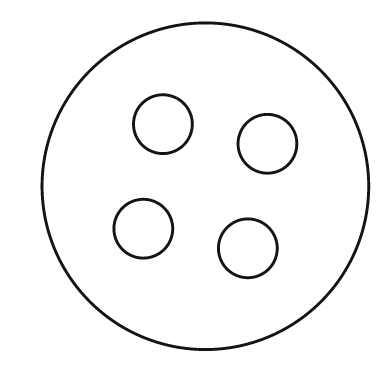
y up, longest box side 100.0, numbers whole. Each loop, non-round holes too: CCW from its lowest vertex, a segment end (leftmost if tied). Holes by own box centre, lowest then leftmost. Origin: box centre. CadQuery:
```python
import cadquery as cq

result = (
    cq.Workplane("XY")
    .moveTo(0.0, 0.0)
    .circle(50.0)
    .moveTo(13.0, -19.0)
    .circle(9.0)
    .moveTo(-19.0, -13.0)
    .circle(9.0)
    .moveTo(19.0, 13.0)
    .circle(9.0)
    .moveTo(-13.0, 19.0)
    .circle(9.0)
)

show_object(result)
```